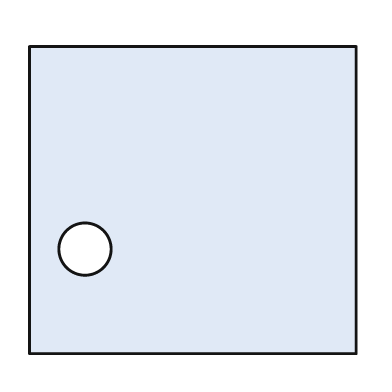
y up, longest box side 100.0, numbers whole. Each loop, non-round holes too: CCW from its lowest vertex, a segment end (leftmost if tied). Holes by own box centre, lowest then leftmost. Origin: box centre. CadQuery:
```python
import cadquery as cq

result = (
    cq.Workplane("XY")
    .moveTo(-50.0, -47.0)
    .lineTo(50.0, -47.0)
    .lineTo(50.0, 47.0)
    .lineTo(-50.0, 47.0)
    .close()
    .moveTo(-33.0, -15.0)
    .circle(8.0)
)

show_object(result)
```